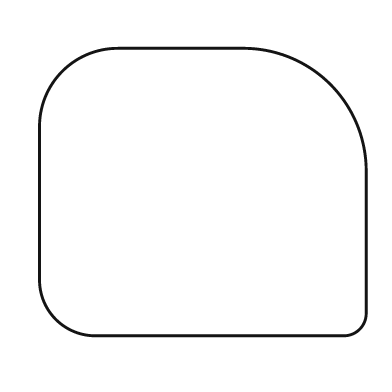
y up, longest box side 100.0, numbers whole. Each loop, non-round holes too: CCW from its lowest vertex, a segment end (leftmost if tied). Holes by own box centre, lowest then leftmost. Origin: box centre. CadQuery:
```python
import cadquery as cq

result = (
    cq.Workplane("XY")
    .moveTo(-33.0, -44.0)
    .lineTo(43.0, -44.0)
    .threePointArc((48.0, -42.0), (50.0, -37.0))
    .lineTo(50.0, 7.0)
    .threePointArc((39.0, 33.0), (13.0, 44.0))
    .lineTo(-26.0, 44.0)
    .threePointArc((-43.0, 37.0), (-50.0, 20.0))
    .lineTo(-50.0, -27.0)
    .threePointArc((-45.0, -39.0), (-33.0, -44.0))
    .close()
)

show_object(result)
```